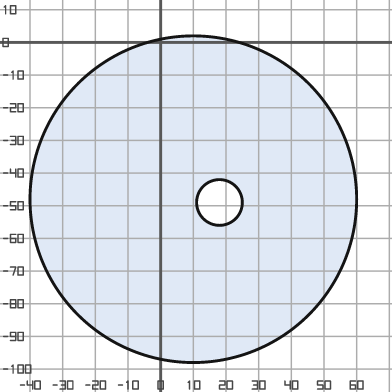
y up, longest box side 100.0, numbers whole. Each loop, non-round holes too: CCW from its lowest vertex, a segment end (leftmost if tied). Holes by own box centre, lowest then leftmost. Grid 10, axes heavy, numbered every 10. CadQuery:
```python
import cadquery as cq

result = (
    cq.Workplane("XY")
    .moveTo(10.0, -48.0)
    .circle(50.0)
    .moveTo(18.0, -49.0)
    .circle(7.0)
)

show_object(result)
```